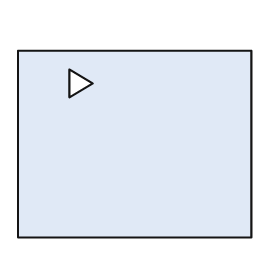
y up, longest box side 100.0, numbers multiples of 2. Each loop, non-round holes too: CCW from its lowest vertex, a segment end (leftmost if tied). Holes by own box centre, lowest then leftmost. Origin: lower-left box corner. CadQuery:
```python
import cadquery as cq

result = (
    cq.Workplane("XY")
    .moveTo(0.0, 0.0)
    .lineTo(100.0, 0.0)
    .lineTo(100.0, 80.0)
    .lineTo(0.0, 80.0)
    .close()
    .moveTo(22.0, 60.0)
    .lineTo(32.0, 66.0)
    .lineTo(22.0, 72.0)
    .close()
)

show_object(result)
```